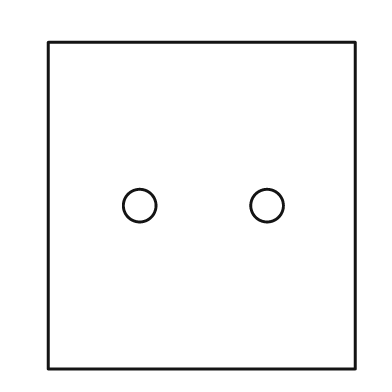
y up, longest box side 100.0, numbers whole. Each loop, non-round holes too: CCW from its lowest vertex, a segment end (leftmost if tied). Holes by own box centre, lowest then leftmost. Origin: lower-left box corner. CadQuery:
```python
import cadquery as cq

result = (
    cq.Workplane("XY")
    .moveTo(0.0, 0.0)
    .lineTo(94.0, 0.0)
    .lineTo(94.0, 100.0)
    .lineTo(0.0, 100.0)
    .close()
    .moveTo(28.0, 50.0)
    .circle(5.0)
    .moveTo(67.0, 50.0)
    .circle(5.0)
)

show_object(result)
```